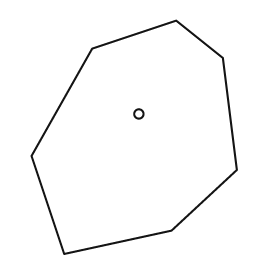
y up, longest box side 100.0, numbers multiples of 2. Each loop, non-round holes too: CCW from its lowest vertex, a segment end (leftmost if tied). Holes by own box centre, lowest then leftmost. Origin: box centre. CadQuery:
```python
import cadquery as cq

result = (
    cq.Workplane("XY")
    .moveTo(-30.0, -50.0)
    .lineTo(16.0, -40.0)
    .lineTo(44.0, -14.0)
    .lineTo(38.0, 34.0)
    .lineTo(18.0, 50.0)
    .lineTo(-18.0, 38.0)
    .lineTo(-44.0, -8.0)
    .close()
    .moveTo(2.0, 10.0)
    .circle(2.0)
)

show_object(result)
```